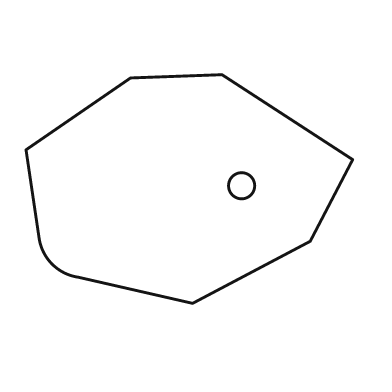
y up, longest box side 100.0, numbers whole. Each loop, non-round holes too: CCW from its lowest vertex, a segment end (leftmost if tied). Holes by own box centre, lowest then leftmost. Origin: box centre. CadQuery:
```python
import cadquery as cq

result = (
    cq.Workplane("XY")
    .moveTo(1.0, -35.0)
    .lineTo(37.0, -16.0)
    .lineTo(50.0, 9.0)
    .lineTo(10.0, 35.0)
    .lineTo(-18.0, 34.0)
    .lineTo(-50.0, 12.0)
    .lineTo(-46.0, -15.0)
    .threePointArc((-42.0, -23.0), (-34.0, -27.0))
    .close()
    .moveTo(16.0, 1.0)
    .circle(4.0)
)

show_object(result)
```